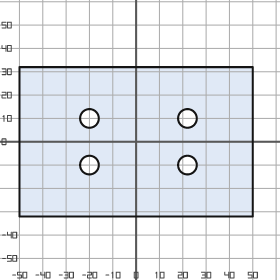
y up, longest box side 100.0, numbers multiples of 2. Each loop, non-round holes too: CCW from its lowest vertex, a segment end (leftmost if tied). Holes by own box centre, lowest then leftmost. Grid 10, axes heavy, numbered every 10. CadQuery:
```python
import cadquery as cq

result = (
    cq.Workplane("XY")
    .moveTo(-50.0, -32.0)
    .lineTo(50.0, -32.0)
    .lineTo(50.0, 32.0)
    .lineTo(-50.0, 32.0)
    .close()
    .moveTo(-20.0, -10.0)
    .circle(4.0)
    .moveTo(22.0, -10.0)
    .circle(4.0)
    .moveTo(-20.0, 10.0)
    .circle(4.0)
    .moveTo(22.0, 10.0)
    .circle(4.0)
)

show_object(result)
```